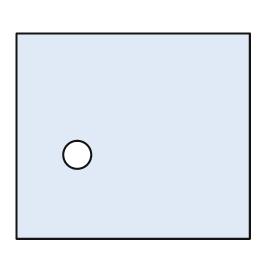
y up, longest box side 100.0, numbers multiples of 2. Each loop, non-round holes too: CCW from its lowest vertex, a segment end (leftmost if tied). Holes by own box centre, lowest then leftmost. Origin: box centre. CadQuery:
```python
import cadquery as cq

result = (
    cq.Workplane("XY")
    .moveTo(-50.0, -44.0)
    .lineTo(50.0, -44.0)
    .lineTo(50.0, 44.0)
    .lineTo(-50.0, 44.0)
    .close()
    .moveTo(-24.0, -8.0)
    .circle(6.0)
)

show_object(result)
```